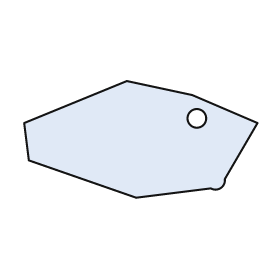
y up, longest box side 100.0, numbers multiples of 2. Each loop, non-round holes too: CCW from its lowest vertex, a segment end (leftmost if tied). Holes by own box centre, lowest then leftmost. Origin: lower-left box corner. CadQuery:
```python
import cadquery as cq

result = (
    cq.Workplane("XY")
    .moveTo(48.0, 0.0)
    .lineTo(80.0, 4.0)
    .threePointArc((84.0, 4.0), (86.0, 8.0))
    .lineTo(100.0, 32.0)
    .lineTo(72.0, 44.0)
    .lineTo(44.0, 50.0)
    .lineTo(0.0, 32.0)
    .lineTo(2.0, 16.0)
    .close()
    .moveTo(74.0, 34.0)
    .circle(4.0)
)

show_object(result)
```